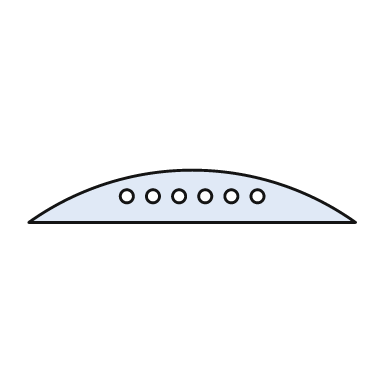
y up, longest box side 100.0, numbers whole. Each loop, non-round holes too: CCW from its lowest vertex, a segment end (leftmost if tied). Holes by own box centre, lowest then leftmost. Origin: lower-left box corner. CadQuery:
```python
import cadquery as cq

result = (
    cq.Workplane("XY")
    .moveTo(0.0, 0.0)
    .lineTo(100.0, 0.0)
    .threePointArc((50.0, 16.0), (0.0, 0.0))
    .close()
    .moveTo(30.0, 8.0)
    .circle(2.0)
    .moveTo(38.0, 8.0)
    .circle(2.0)
    .moveTo(46.0, 8.0)
    .circle(2.0)
    .moveTo(54.0, 8.0)
    .circle(2.0)
    .moveTo(62.0, 8.0)
    .circle(2.0)
    .moveTo(70.0, 8.0)
    .circle(2.0)
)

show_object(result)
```